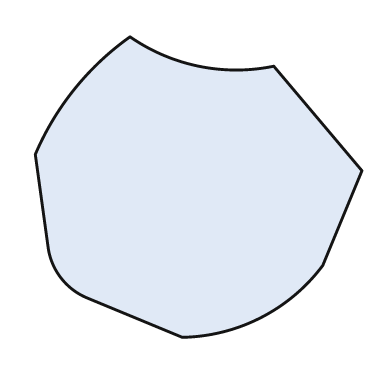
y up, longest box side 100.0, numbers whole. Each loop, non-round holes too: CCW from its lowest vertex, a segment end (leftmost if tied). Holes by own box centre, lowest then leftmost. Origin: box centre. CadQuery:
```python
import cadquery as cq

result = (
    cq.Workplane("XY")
    .moveTo(-5.0, -46.0)
    .threePointArc((19.0, -40.0), (38.0, -24.0))
    .lineTo(50.0, 5.0)
    .lineTo(23.0, 37.0)
    .threePointArc((0.0, 37.0), (-21.0, 46.0))
    .threePointArc((-38.0, 30.0), (-50.0, 10.0))
    .lineTo(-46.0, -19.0)
    .threePointArc((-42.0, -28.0), (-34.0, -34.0))
    .close()
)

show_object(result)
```